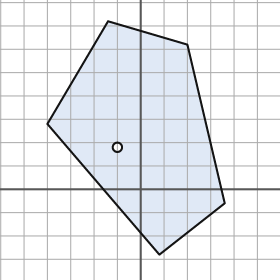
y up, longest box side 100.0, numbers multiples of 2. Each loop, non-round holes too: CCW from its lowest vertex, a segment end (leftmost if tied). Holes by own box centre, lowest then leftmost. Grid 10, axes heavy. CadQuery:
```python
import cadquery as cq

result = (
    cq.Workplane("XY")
    .moveTo(8.0, -28.0)
    .lineTo(36.0, -6.0)
    .lineTo(20.0, 62.0)
    .lineTo(-14.0, 72.0)
    .lineTo(-40.0, 28.0)
    .close()
    .moveTo(-10.0, 18.0)
    .circle(2.0)
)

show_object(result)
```